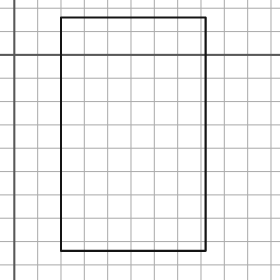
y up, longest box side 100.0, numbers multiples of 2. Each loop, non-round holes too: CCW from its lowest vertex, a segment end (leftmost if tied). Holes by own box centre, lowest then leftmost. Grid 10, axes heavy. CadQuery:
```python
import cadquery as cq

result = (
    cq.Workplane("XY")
    .moveTo(20.0, -84.0)
    .lineTo(82.0, -84.0)
    .lineTo(82.0, 16.0)
    .lineTo(20.0, 16.0)
    .close()
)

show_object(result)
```